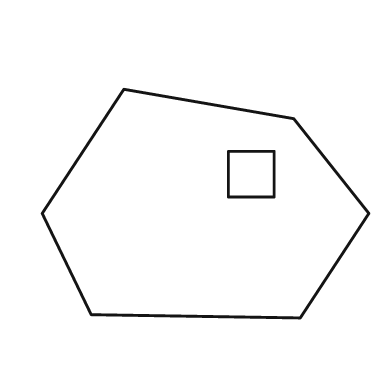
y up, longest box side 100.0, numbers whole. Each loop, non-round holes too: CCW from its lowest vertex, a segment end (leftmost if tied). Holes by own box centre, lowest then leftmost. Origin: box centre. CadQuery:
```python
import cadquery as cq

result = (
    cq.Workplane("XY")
    .moveTo(29.0, -35.0)
    .lineTo(50.0, -3.0)
    .lineTo(27.0, 26.0)
    .lineTo(-25.0, 35.0)
    .lineTo(-50.0, -3.0)
    .lineTo(-35.0, -34.0)
    .close()
    .moveTo(7.0, 2.0)
    .lineTo(21.0, 2.0)
    .lineTo(21.0, 16.0)
    .lineTo(7.0, 16.0)
    .close()
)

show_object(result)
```